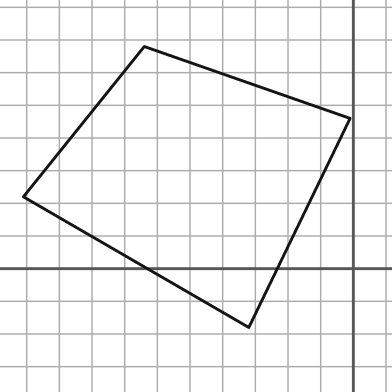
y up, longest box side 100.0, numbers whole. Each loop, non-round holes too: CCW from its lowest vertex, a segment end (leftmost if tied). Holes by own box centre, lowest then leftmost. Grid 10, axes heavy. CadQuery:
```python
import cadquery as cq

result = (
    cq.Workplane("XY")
    .moveTo(-32.0, -18.0)
    .lineTo(-1.0, 46.0)
    .lineTo(-64.0, 68.0)
    .lineTo(-101.0, 22.0)
    .close()
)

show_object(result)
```